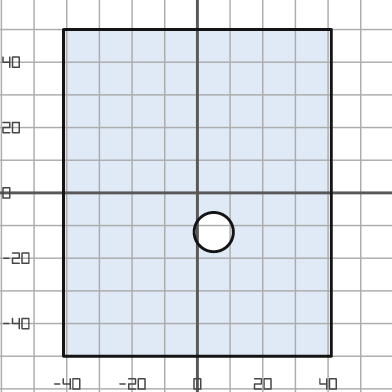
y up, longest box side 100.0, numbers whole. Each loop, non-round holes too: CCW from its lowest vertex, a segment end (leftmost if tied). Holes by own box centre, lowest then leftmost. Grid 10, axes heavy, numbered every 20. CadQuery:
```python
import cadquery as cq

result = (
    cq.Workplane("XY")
    .moveTo(-41.0, -50.0)
    .lineTo(41.0, -50.0)
    .lineTo(41.0, 50.0)
    .lineTo(-41.0, 50.0)
    .close()
    .moveTo(5.0, -12.0)
    .circle(6.0)
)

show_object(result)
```